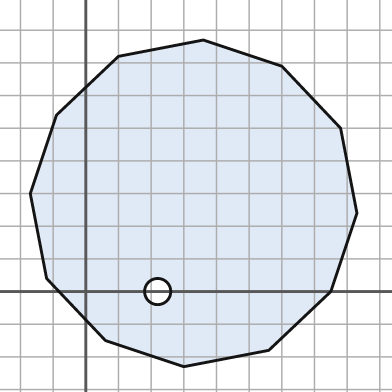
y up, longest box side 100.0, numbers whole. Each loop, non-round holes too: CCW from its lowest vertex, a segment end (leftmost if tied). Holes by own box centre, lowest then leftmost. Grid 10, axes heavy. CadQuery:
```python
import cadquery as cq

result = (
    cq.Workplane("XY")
    .moveTo(30.0, -23.0)
    .lineTo(56.0, -18.0)
    .lineTo(75.0, 0.0)
    .lineTo(83.0, 24.0)
    .lineTo(78.0, 50.0)
    .lineTo(60.0, 69.0)
    .lineTo(36.0, 77.0)
    .lineTo(10.0, 72.0)
    .lineTo(-9.0, 54.0)
    .lineTo(-17.0, 30.0)
    .lineTo(-12.0, 4.0)
    .lineTo(6.0, -15.0)
    .close()
    .moveTo(22.0, 0.0)
    .circle(4.0)
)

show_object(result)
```